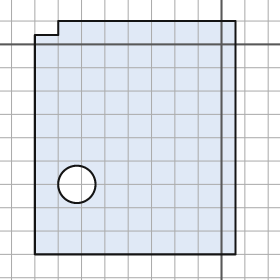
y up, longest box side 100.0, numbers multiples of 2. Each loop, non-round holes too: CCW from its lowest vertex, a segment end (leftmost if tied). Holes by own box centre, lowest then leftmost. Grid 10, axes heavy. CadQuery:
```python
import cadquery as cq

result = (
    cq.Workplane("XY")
    .moveTo(-80.0, -90.0)
    .lineTo(6.0, -90.0)
    .lineTo(6.0, 10.0)
    .lineTo(-70.0, 10.0)
    .lineTo(-70.0, 4.0)
    .lineTo(-80.0, 4.0)
    .close()
    .moveTo(-62.0, -60.0)
    .circle(8.0)
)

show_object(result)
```